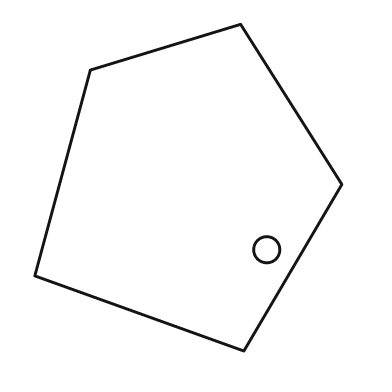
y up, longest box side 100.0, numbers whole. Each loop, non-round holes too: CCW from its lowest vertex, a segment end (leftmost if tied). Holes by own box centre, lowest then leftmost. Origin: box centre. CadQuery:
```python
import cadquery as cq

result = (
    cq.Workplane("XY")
    .moveTo(17.0, -50.0)
    .lineTo(47.0, 1.0)
    .lineTo(16.0, 50.0)
    .lineTo(-30.0, 36.0)
    .lineTo(-47.0, -27.0)
    .close()
    .moveTo(24.0, -19.0)
    .circle(4.0)
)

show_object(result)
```